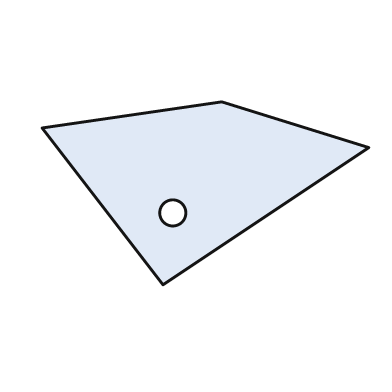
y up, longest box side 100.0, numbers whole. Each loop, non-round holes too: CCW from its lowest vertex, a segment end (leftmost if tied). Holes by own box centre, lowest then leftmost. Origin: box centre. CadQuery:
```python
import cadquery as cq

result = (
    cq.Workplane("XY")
    .moveTo(-13.0, -28.0)
    .lineTo(50.0, 14.0)
    .lineTo(5.0, 28.0)
    .lineTo(-50.0, 20.0)
    .close()
    .moveTo(-10.0, -6.0)
    .circle(4.0)
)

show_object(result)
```